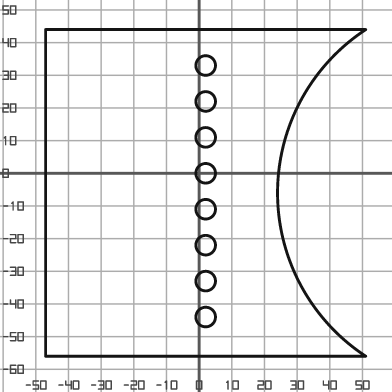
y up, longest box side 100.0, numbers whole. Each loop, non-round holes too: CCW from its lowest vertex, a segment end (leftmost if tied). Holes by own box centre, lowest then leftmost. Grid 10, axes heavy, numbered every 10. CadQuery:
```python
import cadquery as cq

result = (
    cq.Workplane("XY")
    .moveTo(-47.0, -56.0)
    .lineTo(51.0, -56.0)
    .threePointArc((24.0, -6.0), (51.0, 44.0))
    .lineTo(-47.0, 44.0)
    .close()
    .moveTo(2.0, -44.0)
    .circle(3.0)
    .moveTo(2.0, -33.0)
    .circle(3.0)
    .moveTo(2.0, -22.0)
    .circle(3.0)
    .moveTo(2.0, -11.0)
    .circle(3.0)
    .moveTo(2.0, 0.0)
    .circle(3.0)
    .moveTo(2.0, 11.0)
    .circle(3.0)
    .moveTo(2.0, 22.0)
    .circle(3.0)
    .moveTo(2.0, 33.0)
    .circle(3.0)
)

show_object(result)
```